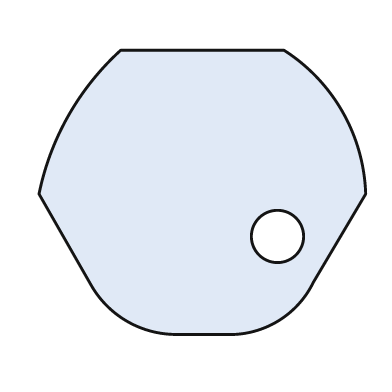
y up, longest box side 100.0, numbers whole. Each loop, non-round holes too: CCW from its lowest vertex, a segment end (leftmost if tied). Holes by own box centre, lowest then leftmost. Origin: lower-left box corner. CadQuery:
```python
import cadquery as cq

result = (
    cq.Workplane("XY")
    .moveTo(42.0, 0.0)
    .lineTo(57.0, 0.0)
    .threePointArc((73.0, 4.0), (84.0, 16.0))
    .lineTo(100.0, 43.0)
    .threePointArc((93.0, 68.0), (75.0, 87.0))
    .lineTo(25.0, 87.0)
    .threePointArc((9.0, 67.0), (0.0, 43.0))
    .lineTo(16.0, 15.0)
    .threePointArc((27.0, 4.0), (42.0, 0.0))
    .close()
    .moveTo(73.0, 30.0)
    .circle(8.0)
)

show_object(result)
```